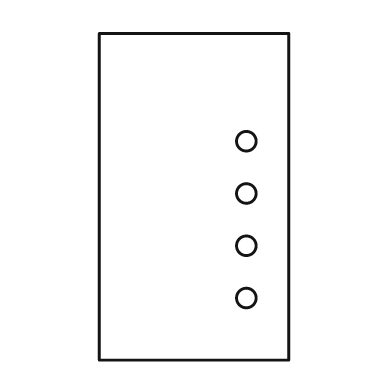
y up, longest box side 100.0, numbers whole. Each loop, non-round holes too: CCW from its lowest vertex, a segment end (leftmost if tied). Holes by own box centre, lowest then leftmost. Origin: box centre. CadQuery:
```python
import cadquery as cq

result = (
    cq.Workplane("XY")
    .moveTo(-29.0, -50.0)
    .lineTo(29.0, -50.0)
    .lineTo(29.0, 50.0)
    .lineTo(-29.0, 50.0)
    .close()
    .moveTo(16.0, -31.0)
    .circle(3.0)
    .moveTo(16.0, -15.0)
    .circle(3.0)
    .moveTo(16.0, 1.0)
    .circle(3.0)
    .moveTo(16.0, 17.0)
    .circle(3.0)
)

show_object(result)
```